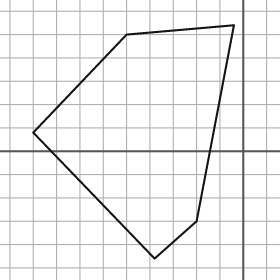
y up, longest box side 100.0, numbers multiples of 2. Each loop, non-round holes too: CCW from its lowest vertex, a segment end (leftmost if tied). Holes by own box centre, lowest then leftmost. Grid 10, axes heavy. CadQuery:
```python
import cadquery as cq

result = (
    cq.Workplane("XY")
    .moveTo(-38.0, -46.0)
    .lineTo(-20.0, -30.0)
    .lineTo(-4.0, 54.0)
    .lineTo(-50.0, 50.0)
    .lineTo(-90.0, 8.0)
    .close()
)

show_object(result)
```